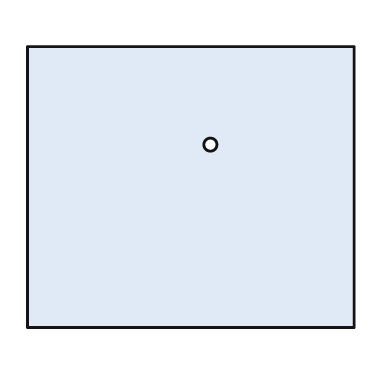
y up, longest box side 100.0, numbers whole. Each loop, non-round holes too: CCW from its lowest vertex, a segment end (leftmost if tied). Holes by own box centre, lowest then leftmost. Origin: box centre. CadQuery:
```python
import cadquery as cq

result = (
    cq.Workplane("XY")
    .moveTo(-50.0, -43.0)
    .lineTo(50.0, -43.0)
    .lineTo(50.0, 43.0)
    .lineTo(-50.0, 43.0)
    .close()
    .moveTo(6.0, 13.0)
    .circle(2.0)
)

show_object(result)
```